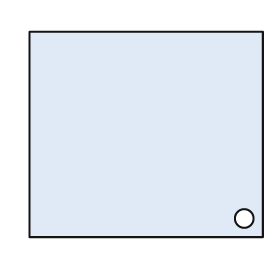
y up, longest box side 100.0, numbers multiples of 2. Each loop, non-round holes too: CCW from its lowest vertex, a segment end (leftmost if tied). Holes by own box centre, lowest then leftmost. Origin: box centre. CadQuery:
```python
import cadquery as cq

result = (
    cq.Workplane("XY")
    .moveTo(-50.0, -44.0)
    .lineTo(50.0, -44.0)
    .lineTo(50.0, 44.0)
    .lineTo(-50.0, 44.0)
    .close()
    .moveTo(42.0, -36.0)
    .circle(4.0)
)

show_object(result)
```